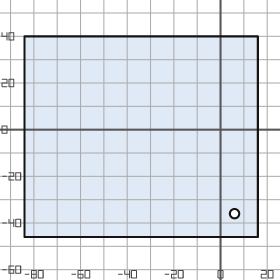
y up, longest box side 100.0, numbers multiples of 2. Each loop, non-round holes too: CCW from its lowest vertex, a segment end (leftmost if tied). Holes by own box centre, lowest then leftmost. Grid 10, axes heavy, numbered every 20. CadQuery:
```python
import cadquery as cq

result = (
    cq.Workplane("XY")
    .moveTo(-84.0, -46.0)
    .lineTo(16.0, -46.0)
    .lineTo(16.0, 40.0)
    .lineTo(-84.0, 40.0)
    .close()
    .moveTo(6.0, -36.0)
    .circle(2.0)
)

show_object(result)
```